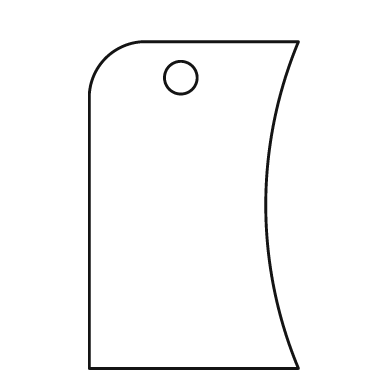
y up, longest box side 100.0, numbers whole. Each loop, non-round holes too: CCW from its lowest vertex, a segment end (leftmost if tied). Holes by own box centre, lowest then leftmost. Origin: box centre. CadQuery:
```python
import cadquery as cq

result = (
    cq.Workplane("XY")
    .moveTo(-32.0, -50.0)
    .lineTo(32.0, -50.0)
    .threePointArc((22.0, 0.0), (32.0, 50.0))
    .lineTo(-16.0, 50.0)
    .threePointArc((-27.0, 45.0), (-32.0, 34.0))
    .close()
    .moveTo(-4.0, 39.0)
    .circle(5.0)
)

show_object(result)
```